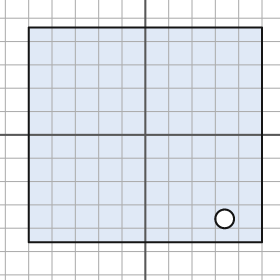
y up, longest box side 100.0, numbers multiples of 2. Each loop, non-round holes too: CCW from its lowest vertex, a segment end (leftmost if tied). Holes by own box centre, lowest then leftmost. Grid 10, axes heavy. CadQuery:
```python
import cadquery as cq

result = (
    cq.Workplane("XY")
    .moveTo(-50.0, -46.0)
    .lineTo(50.0, -46.0)
    .lineTo(50.0, 46.0)
    .lineTo(-50.0, 46.0)
    .close()
    .moveTo(34.0, -36.0)
    .circle(4.0)
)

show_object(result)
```